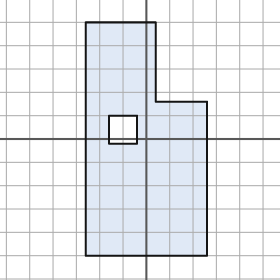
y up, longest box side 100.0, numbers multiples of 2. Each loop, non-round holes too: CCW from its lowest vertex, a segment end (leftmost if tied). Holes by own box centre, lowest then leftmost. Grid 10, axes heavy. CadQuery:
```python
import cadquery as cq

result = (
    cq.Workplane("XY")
    .moveTo(-26.0, -50.0)
    .lineTo(26.0, -50.0)
    .lineTo(26.0, 16.0)
    .lineTo(4.0, 16.0)
    .lineTo(4.0, 50.0)
    .lineTo(-26.0, 50.0)
    .close()
    .moveTo(-16.0, -2.0)
    .lineTo(-4.0, -2.0)
    .lineTo(-4.0, 10.0)
    .lineTo(-16.0, 10.0)
    .close()
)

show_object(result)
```